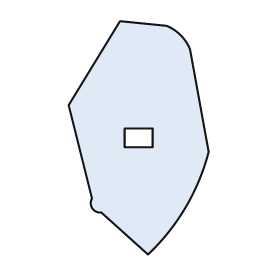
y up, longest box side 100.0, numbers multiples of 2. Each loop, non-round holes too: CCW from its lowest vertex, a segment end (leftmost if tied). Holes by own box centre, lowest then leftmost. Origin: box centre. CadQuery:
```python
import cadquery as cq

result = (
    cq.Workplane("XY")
    .moveTo(4.0, -50.0)
    .threePointArc((20.0, -30.0), (30.0, -6.0))
    .lineTo(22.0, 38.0)
    .threePointArc((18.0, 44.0), (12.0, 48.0))
    .lineTo(-8.0, 50.0)
    .lineTo(-30.0, 14.0)
    .lineTo(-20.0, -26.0)
    .threePointArc((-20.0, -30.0), (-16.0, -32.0))
    .close()
    .moveTo(-6.0, -4.0)
    .lineTo(6.0, -4.0)
    .lineTo(6.0, 4.0)
    .lineTo(-6.0, 4.0)
    .close()
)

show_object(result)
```